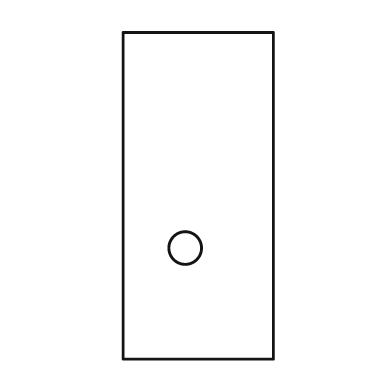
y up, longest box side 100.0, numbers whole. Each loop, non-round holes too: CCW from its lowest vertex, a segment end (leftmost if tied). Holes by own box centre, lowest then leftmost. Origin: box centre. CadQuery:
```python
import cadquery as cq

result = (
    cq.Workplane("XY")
    .moveTo(-23.0, -50.0)
    .lineTo(23.0, -50.0)
    .lineTo(23.0, 50.0)
    .lineTo(-23.0, 50.0)
    .close()
    .moveTo(-4.0, -16.0)
    .circle(5.0)
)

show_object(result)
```